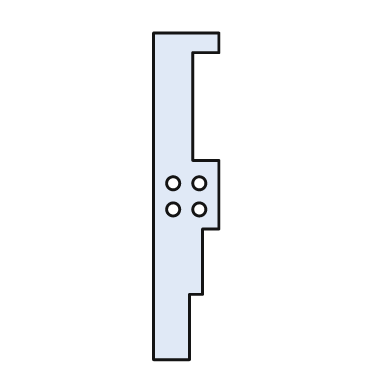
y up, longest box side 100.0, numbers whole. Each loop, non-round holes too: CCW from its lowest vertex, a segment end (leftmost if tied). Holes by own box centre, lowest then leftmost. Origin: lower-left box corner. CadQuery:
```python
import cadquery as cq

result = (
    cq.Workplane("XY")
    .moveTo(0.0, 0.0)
    .lineTo(11.0, 0.0)
    .lineTo(11.0, 20.0)
    .lineTo(15.0, 20.0)
    .lineTo(15.0, 40.0)
    .lineTo(20.0, 40.0)
    .lineTo(20.0, 61.0)
    .lineTo(12.0, 61.0)
    .lineTo(12.0, 94.0)
    .lineTo(20.0, 94.0)
    .lineTo(20.0, 100.0)
    .lineTo(0.0, 100.0)
    .close()
    .moveTo(6.0, 46.0)
    .circle(2.0)
    .moveTo(14.0, 46.0)
    .circle(2.0)
    .moveTo(6.0, 54.0)
    .circle(2.0)
    .moveTo(14.0, 54.0)
    .circle(2.0)
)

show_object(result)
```